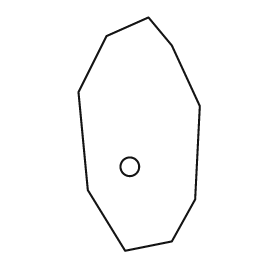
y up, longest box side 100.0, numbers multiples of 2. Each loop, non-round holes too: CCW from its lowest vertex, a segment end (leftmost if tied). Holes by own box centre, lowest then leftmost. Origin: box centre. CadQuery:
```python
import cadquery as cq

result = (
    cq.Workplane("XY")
    .moveTo(-6.0, -50.0)
    .lineTo(14.0, -46.0)
    .lineTo(24.0, -28.0)
    .lineTo(26.0, 12.0)
    .lineTo(14.0, 38.0)
    .lineTo(4.0, 50.0)
    .lineTo(-14.0, 42.0)
    .lineTo(-26.0, 18.0)
    .lineTo(-22.0, -24.0)
    .close()
    .moveTo(-4.0, -14.0)
    .circle(4.0)
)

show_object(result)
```